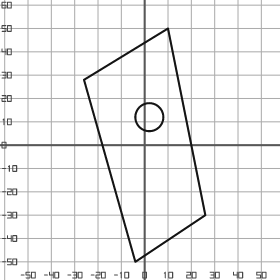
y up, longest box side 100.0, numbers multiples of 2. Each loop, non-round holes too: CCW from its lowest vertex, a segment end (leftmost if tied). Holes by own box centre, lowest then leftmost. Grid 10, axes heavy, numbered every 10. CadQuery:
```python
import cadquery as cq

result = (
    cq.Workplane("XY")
    .moveTo(-4.0, -50.0)
    .lineTo(26.0, -30.0)
    .lineTo(10.0, 50.0)
    .lineTo(-26.0, 28.0)
    .close()
    .moveTo(2.0, 12.0)
    .circle(6.0)
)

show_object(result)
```